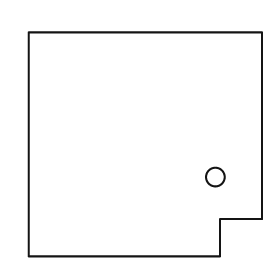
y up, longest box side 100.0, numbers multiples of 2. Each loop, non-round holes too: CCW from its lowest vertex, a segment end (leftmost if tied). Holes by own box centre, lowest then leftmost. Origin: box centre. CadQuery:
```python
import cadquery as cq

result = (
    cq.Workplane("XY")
    .moveTo(-50.0, -48.0)
    .lineTo(32.0, -48.0)
    .lineTo(32.0, -32.0)
    .lineTo(50.0, -32.0)
    .lineTo(50.0, 48.0)
    .lineTo(-50.0, 48.0)
    .close()
    .moveTo(30.0, -14.0)
    .circle(4.0)
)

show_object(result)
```